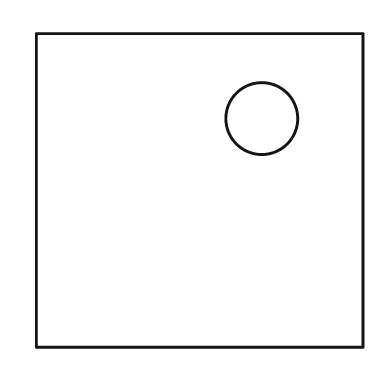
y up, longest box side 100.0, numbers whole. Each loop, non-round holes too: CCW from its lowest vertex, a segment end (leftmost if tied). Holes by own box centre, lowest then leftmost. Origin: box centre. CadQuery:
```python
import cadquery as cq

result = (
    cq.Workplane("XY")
    .moveTo(-50.0, -48.0)
    .lineTo(50.0, -48.0)
    .lineTo(50.0, 48.0)
    .lineTo(-50.0, 48.0)
    .close()
    .moveTo(19.0, 22.0)
    .circle(11.0)
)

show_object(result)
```